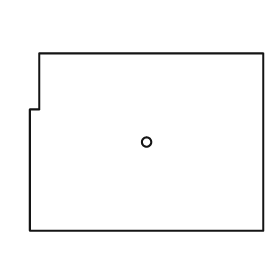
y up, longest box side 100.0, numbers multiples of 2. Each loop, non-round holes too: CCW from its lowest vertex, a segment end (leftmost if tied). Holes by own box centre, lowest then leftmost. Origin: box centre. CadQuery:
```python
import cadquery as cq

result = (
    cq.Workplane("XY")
    .moveTo(-50.0, -38.0)
    .lineTo(50.0, -38.0)
    .lineTo(50.0, 38.0)
    .lineTo(-46.0, 38.0)
    .lineTo(-46.0, 14.0)
    .lineTo(-50.0, 14.0)
    .close()
    .moveTo(0.0, 0.0)
    .circle(2.0)
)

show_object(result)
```